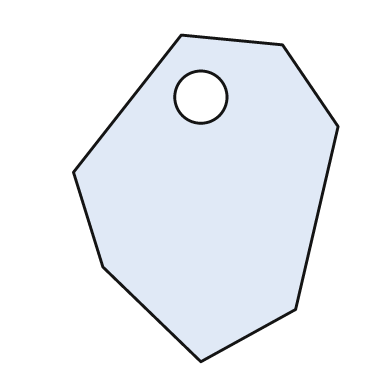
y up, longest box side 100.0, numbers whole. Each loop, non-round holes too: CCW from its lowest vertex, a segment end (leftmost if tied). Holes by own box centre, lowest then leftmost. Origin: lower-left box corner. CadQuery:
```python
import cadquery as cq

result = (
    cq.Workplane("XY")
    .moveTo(39.0, 0.0)
    .lineTo(68.0, 16.0)
    .lineTo(81.0, 72.0)
    .lineTo(64.0, 97.0)
    .lineTo(33.0, 100.0)
    .lineTo(0.0, 58.0)
    .lineTo(9.0, 29.0)
    .close()
    .moveTo(39.0, 81.0)
    .circle(8.0)
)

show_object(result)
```